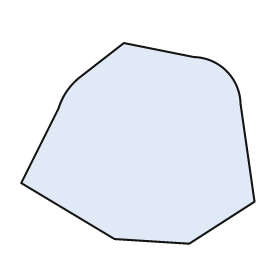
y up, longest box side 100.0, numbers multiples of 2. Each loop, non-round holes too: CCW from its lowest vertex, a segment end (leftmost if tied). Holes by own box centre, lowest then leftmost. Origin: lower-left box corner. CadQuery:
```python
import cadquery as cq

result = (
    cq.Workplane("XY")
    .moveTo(72.0, 0.0)
    .lineTo(100.0, 18.0)
    .lineTo(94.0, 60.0)
    .threePointArc((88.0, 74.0), (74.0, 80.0))
    .lineTo(44.0, 86.0)
    .lineTo(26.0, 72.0)
    .threePointArc((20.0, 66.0), (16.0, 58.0))
    .lineTo(0.0, 26.0)
    .lineTo(40.0, 2.0)
    .close()
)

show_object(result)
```